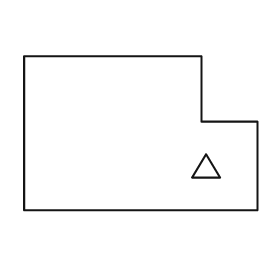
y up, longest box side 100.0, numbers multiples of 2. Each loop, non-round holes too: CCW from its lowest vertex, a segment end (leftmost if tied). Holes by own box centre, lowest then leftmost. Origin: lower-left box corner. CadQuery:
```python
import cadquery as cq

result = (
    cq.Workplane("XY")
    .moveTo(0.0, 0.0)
    .lineTo(100.0, 0.0)
    .lineTo(100.0, 38.0)
    .lineTo(76.0, 38.0)
    .lineTo(76.0, 66.0)
    .lineTo(0.0, 66.0)
    .close()
    .moveTo(72.0, 14.0)
    .lineTo(84.0, 14.0)
    .lineTo(78.0, 24.0)
    .close()
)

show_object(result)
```